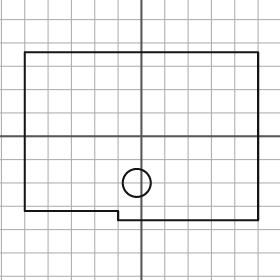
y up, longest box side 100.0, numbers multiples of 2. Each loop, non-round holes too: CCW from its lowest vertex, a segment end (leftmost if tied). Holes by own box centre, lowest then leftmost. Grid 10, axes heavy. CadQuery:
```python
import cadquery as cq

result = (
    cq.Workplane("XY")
    .moveTo(-10.0, -36.0)
    .lineTo(50.0, -36.0)
    .lineTo(50.0, 36.0)
    .lineTo(-50.0, 36.0)
    .lineTo(-50.0, -32.0)
    .lineTo(-10.0, -32.0)
    .close()
    .moveTo(-2.0, -20.0)
    .circle(6.0)
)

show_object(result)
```